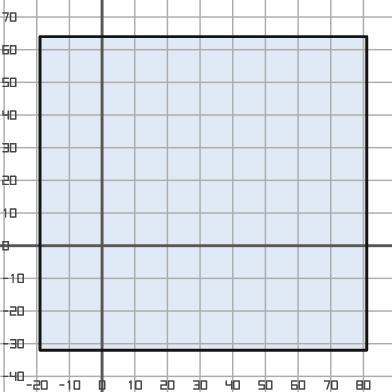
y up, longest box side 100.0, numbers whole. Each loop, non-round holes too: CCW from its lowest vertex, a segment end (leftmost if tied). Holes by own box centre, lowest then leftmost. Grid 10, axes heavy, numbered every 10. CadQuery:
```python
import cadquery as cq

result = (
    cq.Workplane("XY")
    .moveTo(-19.0, -32.0)
    .lineTo(81.0, -32.0)
    .lineTo(81.0, 64.0)
    .lineTo(-19.0, 64.0)
    .close()
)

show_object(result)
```